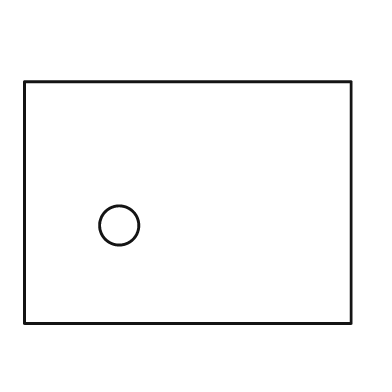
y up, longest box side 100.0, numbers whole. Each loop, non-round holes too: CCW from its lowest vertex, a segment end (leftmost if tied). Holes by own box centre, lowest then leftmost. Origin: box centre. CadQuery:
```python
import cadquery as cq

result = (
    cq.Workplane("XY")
    .moveTo(-50.0, -37.0)
    .lineTo(50.0, -37.0)
    .lineTo(50.0, 37.0)
    .lineTo(-50.0, 37.0)
    .close()
    .moveTo(-21.0, -7.0)
    .circle(6.0)
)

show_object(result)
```